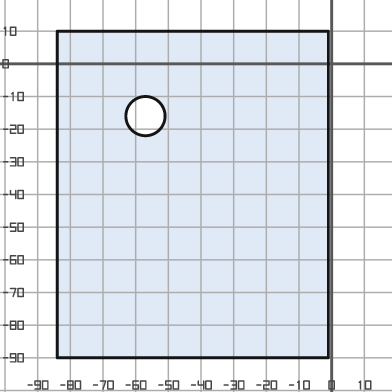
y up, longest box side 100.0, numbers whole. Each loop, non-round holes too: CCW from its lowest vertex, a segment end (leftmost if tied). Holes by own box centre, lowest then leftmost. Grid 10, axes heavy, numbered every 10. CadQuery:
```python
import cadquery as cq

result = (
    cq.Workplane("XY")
    .moveTo(-84.0, -90.0)
    .lineTo(-1.0, -90.0)
    .lineTo(-1.0, 10.0)
    .lineTo(-84.0, 10.0)
    .close()
    .moveTo(-57.0, -16.0)
    .circle(6.0)
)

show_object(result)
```